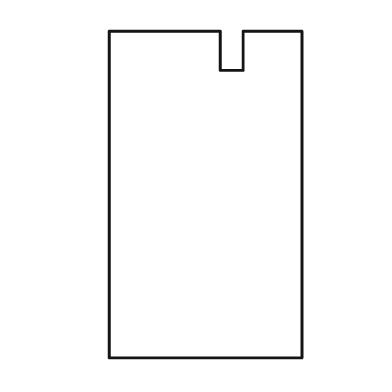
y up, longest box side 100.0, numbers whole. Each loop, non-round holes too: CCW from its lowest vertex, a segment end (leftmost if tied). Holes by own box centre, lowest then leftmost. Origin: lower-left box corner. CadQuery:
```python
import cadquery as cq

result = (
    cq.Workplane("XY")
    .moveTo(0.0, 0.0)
    .lineTo(59.0, 0.0)
    .lineTo(59.0, 100.0)
    .lineTo(41.0, 100.0)
    .lineTo(41.0, 88.0)
    .lineTo(34.0, 88.0)
    .lineTo(34.0, 100.0)
    .lineTo(0.0, 100.0)
    .close()
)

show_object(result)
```